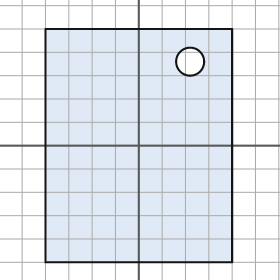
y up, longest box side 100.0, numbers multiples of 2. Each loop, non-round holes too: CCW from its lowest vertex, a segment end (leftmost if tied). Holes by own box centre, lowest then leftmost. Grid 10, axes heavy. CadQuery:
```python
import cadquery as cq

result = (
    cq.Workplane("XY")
    .moveTo(-40.0, -50.0)
    .lineTo(40.0, -50.0)
    .lineTo(40.0, 50.0)
    .lineTo(-40.0, 50.0)
    .close()
    .moveTo(22.0, 36.0)
    .circle(6.0)
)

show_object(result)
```